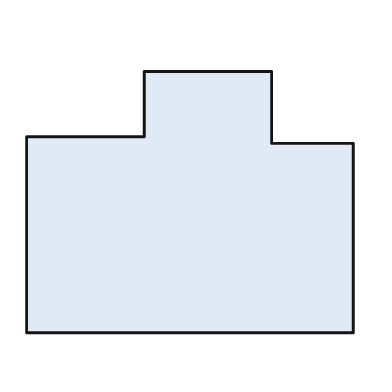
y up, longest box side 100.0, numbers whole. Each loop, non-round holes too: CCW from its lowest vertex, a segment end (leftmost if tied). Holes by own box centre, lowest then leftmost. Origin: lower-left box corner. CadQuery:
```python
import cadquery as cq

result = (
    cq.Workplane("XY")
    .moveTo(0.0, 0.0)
    .lineTo(100.0, 0.0)
    .lineTo(100.0, 58.0)
    .lineTo(75.0, 58.0)
    .lineTo(75.0, 80.0)
    .lineTo(36.0, 80.0)
    .lineTo(36.0, 60.0)
    .lineTo(0.0, 60.0)
    .close()
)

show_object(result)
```